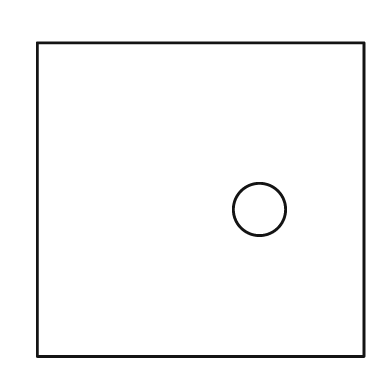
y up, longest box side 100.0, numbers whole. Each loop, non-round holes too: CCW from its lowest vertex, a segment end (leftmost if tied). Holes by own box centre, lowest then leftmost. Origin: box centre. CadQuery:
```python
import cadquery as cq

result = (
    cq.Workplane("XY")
    .moveTo(-50.0, -48.0)
    .lineTo(50.0, -48.0)
    .lineTo(50.0, 48.0)
    .lineTo(-50.0, 48.0)
    .close()
    .moveTo(18.0, -3.0)
    .circle(8.0)
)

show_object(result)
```